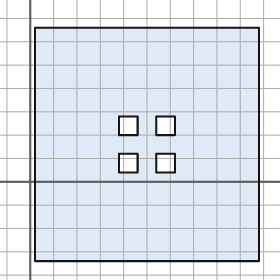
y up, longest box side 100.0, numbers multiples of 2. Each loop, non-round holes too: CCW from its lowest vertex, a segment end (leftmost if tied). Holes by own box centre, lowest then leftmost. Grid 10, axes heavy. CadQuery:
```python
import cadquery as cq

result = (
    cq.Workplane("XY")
    .moveTo(2.0, -34.0)
    .lineTo(98.0, -34.0)
    .lineTo(98.0, 66.0)
    .lineTo(2.0, 66.0)
    .close()
    .moveTo(38.0, 4.0)
    .lineTo(46.0, 4.0)
    .lineTo(46.0, 12.0)
    .lineTo(38.0, 12.0)
    .close()
    .moveTo(54.0, 4.0)
    .lineTo(62.0, 4.0)
    .lineTo(62.0, 12.0)
    .lineTo(54.0, 12.0)
    .close()
    .moveTo(38.0, 20.0)
    .lineTo(46.0, 20.0)
    .lineTo(46.0, 28.0)
    .lineTo(38.0, 28.0)
    .close()
    .moveTo(54.0, 20.0)
    .lineTo(62.0, 20.0)
    .lineTo(62.0, 28.0)
    .lineTo(54.0, 28.0)
    .close()
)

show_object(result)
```